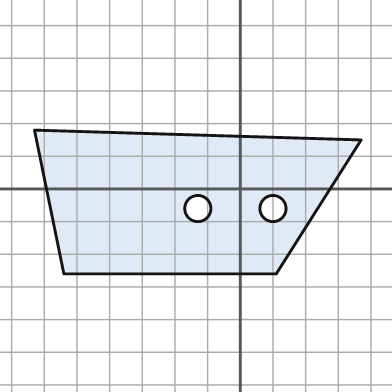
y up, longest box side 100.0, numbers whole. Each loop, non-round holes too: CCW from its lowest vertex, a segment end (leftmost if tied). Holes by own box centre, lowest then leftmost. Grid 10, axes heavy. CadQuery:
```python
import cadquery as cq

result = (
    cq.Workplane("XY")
    .moveTo(-54.0, -26.0)
    .lineTo(11.0, -26.0)
    .lineTo(37.0, 15.0)
    .lineTo(-63.0, 18.0)
    .close()
    .moveTo(-13.0, -6.0)
    .circle(4.0)
    .moveTo(10.0, -6.0)
    .circle(4.0)
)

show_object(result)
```